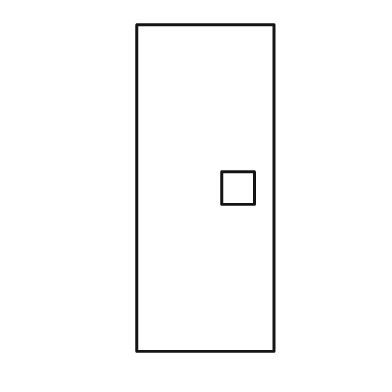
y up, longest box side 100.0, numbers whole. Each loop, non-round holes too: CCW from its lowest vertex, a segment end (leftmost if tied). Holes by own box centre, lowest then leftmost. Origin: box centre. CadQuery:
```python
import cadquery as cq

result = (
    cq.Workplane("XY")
    .moveTo(-21.0, -50.0)
    .lineTo(21.0, -50.0)
    .lineTo(21.0, 50.0)
    .lineTo(-21.0, 50.0)
    .close()
    .moveTo(5.0, -5.0)
    .lineTo(15.0, -5.0)
    .lineTo(15.0, 5.0)
    .lineTo(5.0, 5.0)
    .close()
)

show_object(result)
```